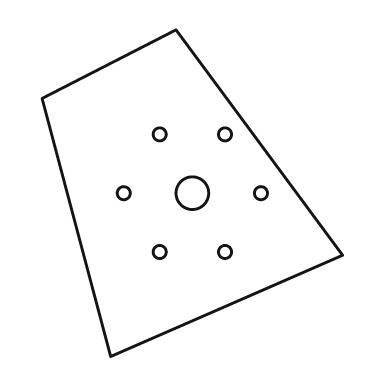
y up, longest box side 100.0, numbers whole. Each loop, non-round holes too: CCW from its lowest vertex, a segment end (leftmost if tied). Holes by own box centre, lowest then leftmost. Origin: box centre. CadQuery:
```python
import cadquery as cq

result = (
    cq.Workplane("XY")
    .moveTo(-25.0, -50.0)
    .lineTo(46.0, -19.0)
    .lineTo(-5.0, 50.0)
    .lineTo(-46.0, 29.0)
    .close()
    .moveTo(-10.0, -18.0)
    .circle(2.0)
    .moveTo(10.0, -18.0)
    .circle(2.0)
    .moveTo(-21.0, 0.0)
    .circle(2.0)
    .moveTo(0.0, 0.0)
    .circle(5.0)
    .moveTo(21.0, 0.0)
    .circle(2.0)
    .moveTo(-10.0, 18.0)
    .circle(2.0)
    .moveTo(10.0, 18.0)
    .circle(2.0)
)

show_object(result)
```